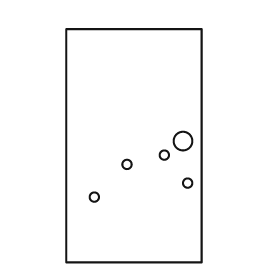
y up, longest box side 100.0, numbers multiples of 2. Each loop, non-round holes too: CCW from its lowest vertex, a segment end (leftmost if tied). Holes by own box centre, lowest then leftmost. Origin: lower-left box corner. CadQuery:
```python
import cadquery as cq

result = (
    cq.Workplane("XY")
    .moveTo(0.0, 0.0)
    .lineTo(58.0, 0.0)
    .lineTo(58.0, 100.0)
    .lineTo(0.0, 100.0)
    .close()
    .moveTo(12.0, 28.0)
    .circle(2.0)
    .moveTo(52.0, 34.0)
    .circle(2.0)
    .moveTo(26.0, 42.0)
    .circle(2.0)
    .moveTo(42.0, 46.0)
    .circle(2.0)
    .moveTo(50.0, 52.0)
    .circle(4.0)
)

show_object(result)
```